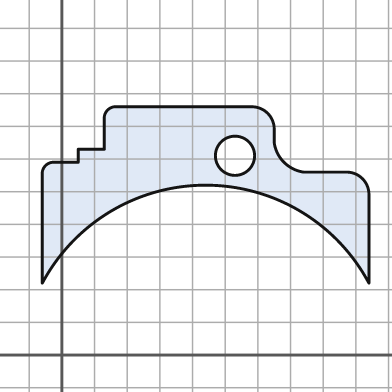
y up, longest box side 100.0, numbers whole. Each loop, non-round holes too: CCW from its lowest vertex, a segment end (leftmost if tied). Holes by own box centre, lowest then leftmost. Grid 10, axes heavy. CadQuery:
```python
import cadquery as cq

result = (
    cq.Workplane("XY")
    .moveTo(-6.0, 22.0)
    .threePointArc((44.0, 52.0), (94.0, 22.0))
    .lineTo(94.0, 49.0)
    .threePointArc((92.0, 54.0), (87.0, 56.0))
    .lineTo(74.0, 56.0)
    .threePointArc((68.0, 59.0), (65.0, 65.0))
    .lineTo(65.0, 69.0)
    .threePointArc((63.0, 74.0), (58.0, 76.0))
    .lineTo(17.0, 76.0)
    .threePointArc((14.0, 75.0), (13.0, 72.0))
    .lineTo(13.0, 63.0)
    .lineTo(5.0, 63.0)
    .lineTo(5.0, 59.0)
    .lineTo(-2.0, 59.0)
    .threePointArc((-5.0, 58.0), (-6.0, 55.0))
    .close()
    .moveTo(53.0, 61.0)
    .circle(6.0)
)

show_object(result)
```